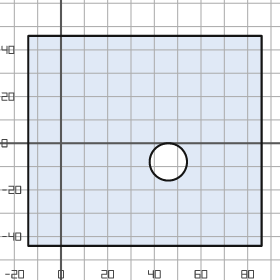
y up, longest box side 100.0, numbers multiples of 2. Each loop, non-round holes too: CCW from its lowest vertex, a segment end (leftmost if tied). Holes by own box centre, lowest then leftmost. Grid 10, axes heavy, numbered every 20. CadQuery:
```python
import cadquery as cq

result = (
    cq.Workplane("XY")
    .moveTo(-14.0, -44.0)
    .lineTo(86.0, -44.0)
    .lineTo(86.0, 46.0)
    .lineTo(-14.0, 46.0)
    .close()
    .moveTo(46.0, -8.0)
    .circle(8.0)
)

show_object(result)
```